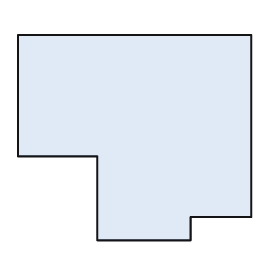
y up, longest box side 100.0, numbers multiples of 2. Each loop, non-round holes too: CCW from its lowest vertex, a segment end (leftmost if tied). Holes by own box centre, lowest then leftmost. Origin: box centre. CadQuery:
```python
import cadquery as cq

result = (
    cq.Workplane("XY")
    .moveTo(-16.0, -44.0)
    .lineTo(24.0, -44.0)
    .lineTo(24.0, -34.0)
    .lineTo(50.0, -34.0)
    .lineTo(50.0, 44.0)
    .lineTo(-50.0, 44.0)
    .lineTo(-50.0, -8.0)
    .lineTo(-16.0, -8.0)
    .close()
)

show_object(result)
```